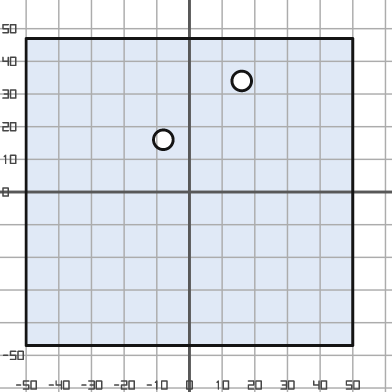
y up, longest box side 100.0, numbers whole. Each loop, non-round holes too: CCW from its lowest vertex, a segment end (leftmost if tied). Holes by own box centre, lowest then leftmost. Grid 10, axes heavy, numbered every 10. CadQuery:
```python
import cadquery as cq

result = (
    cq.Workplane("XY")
    .moveTo(-50.0, -47.0)
    .lineTo(50.0, -47.0)
    .lineTo(50.0, 47.0)
    .lineTo(-50.0, 47.0)
    .close()
    .moveTo(-8.0, 16.0)
    .circle(3.0)
    .moveTo(16.0, 34.0)
    .circle(3.0)
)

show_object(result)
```